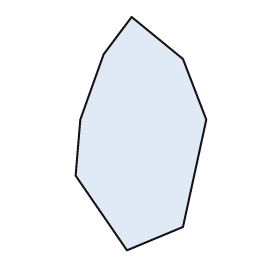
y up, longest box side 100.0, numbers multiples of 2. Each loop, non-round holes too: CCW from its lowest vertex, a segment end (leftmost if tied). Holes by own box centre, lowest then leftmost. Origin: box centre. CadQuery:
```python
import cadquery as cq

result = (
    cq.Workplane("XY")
    .moveTo(-6.0, -50.0)
    .lineTo(18.0, -40.0)
    .lineTo(28.0, 6.0)
    .lineTo(18.0, 32.0)
    .lineTo(-4.0, 50.0)
    .lineTo(-16.0, 34.0)
    .lineTo(-26.0, 6.0)
    .lineTo(-28.0, -18.0)
    .close()
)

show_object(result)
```